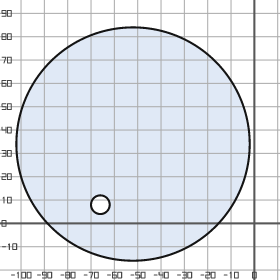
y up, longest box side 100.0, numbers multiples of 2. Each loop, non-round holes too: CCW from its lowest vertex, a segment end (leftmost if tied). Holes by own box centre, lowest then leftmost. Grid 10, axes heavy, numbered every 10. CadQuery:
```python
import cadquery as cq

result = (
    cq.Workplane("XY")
    .moveTo(-52.0, 34.0)
    .circle(50.0)
    .moveTo(-66.0, 8.0)
    .circle(4.0)
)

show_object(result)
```